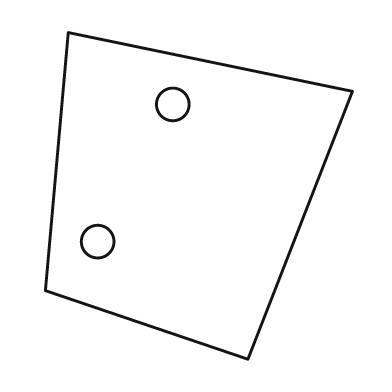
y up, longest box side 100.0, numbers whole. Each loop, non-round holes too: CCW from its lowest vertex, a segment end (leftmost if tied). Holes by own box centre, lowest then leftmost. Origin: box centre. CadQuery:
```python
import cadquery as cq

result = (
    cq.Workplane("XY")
    .moveTo(15.0, -50.0)
    .lineTo(47.0, 32.0)
    .lineTo(-40.0, 50.0)
    .lineTo(-47.0, -29.0)
    .close()
    .moveTo(-31.0, -14.0)
    .circle(5.0)
    .moveTo(-8.0, 28.0)
    .circle(5.0)
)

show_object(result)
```